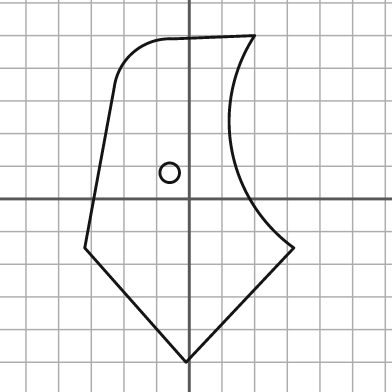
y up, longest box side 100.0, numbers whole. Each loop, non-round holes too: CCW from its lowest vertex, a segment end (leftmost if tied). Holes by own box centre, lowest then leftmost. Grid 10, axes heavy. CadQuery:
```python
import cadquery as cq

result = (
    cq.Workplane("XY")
    .moveTo(-1.0, -50.0)
    .lineTo(32.0, -15.0)
    .threePointArc((13.0, 15.0), (20.0, 50.0))
    .lineTo(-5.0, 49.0)
    .threePointArc((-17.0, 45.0), (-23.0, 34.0))
    .lineTo(-32.0, -15.0)
    .close()
    .moveTo(-6.0, 8.0)
    .circle(3.0)
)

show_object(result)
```